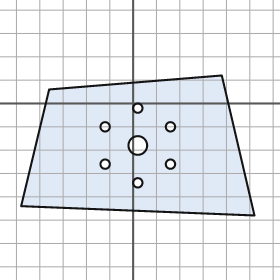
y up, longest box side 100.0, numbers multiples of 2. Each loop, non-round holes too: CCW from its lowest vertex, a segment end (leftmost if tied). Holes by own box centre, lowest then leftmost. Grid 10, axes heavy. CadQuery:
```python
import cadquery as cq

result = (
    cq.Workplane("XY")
    .moveTo(52.0, -48.0)
    .lineTo(38.0, 12.0)
    .lineTo(-36.0, 6.0)
    .lineTo(-48.0, -44.0)
    .close()
    .moveTo(2.0, -34.0)
    .circle(2.0)
    .moveTo(-12.0, -26.0)
    .circle(2.0)
    .moveTo(16.0, -26.0)
    .circle(2.0)
    .moveTo(2.0, -18.0)
    .circle(4.0)
    .moveTo(-12.0, -10.0)
    .circle(2.0)
    .moveTo(16.0, -10.0)
    .circle(2.0)
    .moveTo(2.0, -2.0)
    .circle(2.0)
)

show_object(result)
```